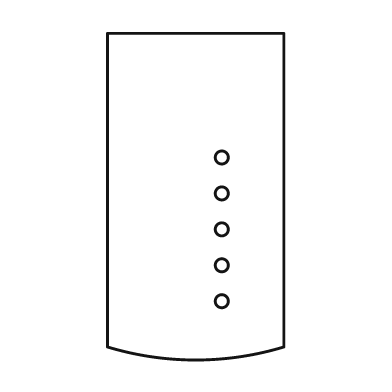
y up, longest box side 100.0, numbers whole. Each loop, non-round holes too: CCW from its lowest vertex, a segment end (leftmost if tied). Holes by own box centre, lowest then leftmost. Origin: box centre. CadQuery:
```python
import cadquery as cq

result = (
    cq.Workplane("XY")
    .moveTo(-27.0, -46.0)
    .threePointArc((0.0, -50.0), (27.0, -46.0))
    .lineTo(27.0, 50.0)
    .lineTo(-27.0, 50.0)
    .close()
    .moveTo(8.0, -32.0)
    .circle(2.0)
    .moveTo(8.0, -21.0)
    .circle(2.0)
    .moveTo(8.0, -10.0)
    .circle(2.0)
    .moveTo(8.0, 1.0)
    .circle(2.0)
    .moveTo(8.0, 12.0)
    .circle(2.0)
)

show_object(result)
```